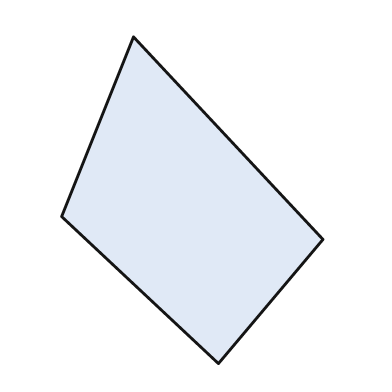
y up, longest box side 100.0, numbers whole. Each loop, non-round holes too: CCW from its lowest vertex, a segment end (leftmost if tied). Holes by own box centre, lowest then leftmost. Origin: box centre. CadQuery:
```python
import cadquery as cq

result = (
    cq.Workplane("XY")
    .moveTo(8.0, -50.0)
    .lineTo(40.0, -12.0)
    .lineTo(-18.0, 50.0)
    .lineTo(-40.0, -5.0)
    .close()
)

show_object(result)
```